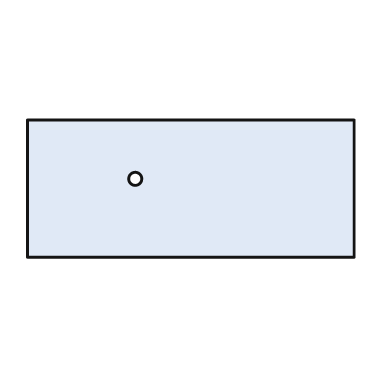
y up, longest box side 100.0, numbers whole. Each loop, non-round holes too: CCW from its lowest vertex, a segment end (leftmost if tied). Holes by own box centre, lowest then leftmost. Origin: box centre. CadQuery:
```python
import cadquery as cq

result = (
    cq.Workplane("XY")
    .moveTo(-50.0, -21.0)
    .lineTo(50.0, -21.0)
    .lineTo(50.0, 21.0)
    .lineTo(-50.0, 21.0)
    .close()
    .moveTo(-17.0, 3.0)
    .circle(2.0)
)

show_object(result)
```